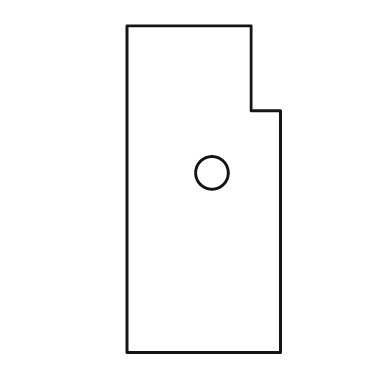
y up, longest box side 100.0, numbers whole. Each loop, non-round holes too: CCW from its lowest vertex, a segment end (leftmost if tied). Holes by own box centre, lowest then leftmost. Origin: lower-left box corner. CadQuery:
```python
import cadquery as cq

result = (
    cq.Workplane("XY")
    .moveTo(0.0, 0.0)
    .lineTo(47.0, 0.0)
    .lineTo(47.0, 74.0)
    .lineTo(38.0, 74.0)
    .lineTo(38.0, 100.0)
    .lineTo(0.0, 100.0)
    .close()
    .moveTo(26.0, 55.0)
    .circle(5.0)
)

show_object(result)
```